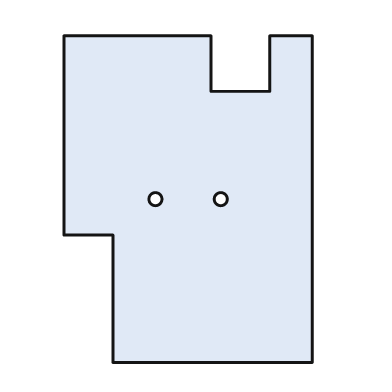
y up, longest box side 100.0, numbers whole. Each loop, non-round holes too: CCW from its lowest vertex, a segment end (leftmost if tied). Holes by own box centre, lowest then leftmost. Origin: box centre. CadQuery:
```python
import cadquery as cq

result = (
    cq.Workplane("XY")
    .moveTo(-23.0, -50.0)
    .lineTo(38.0, -50.0)
    .lineTo(38.0, 50.0)
    .lineTo(25.0, 50.0)
    .lineTo(25.0, 33.0)
    .lineTo(7.0, 33.0)
    .lineTo(7.0, 50.0)
    .lineTo(-38.0, 50.0)
    .lineTo(-38.0, -11.0)
    .lineTo(-23.0, -11.0)
    .close()
    .moveTo(-10.0, 0.0)
    .circle(2.0)
    .moveTo(10.0, 0.0)
    .circle(2.0)
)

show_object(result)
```